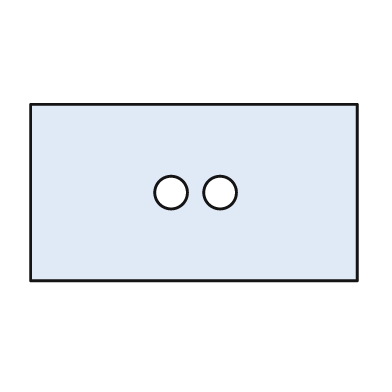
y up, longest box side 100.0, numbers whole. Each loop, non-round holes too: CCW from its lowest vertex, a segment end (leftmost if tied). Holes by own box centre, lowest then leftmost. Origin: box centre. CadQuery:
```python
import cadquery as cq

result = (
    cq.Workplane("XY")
    .moveTo(-50.0, -27.0)
    .lineTo(50.0, -27.0)
    .lineTo(50.0, 27.0)
    .lineTo(-50.0, 27.0)
    .close()
    .moveTo(-7.0, 0.0)
    .circle(5.0)
    .moveTo(8.0, 0.0)
    .circle(5.0)
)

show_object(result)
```